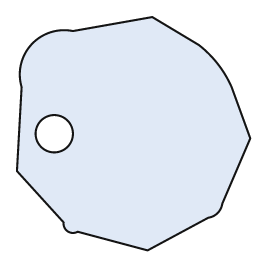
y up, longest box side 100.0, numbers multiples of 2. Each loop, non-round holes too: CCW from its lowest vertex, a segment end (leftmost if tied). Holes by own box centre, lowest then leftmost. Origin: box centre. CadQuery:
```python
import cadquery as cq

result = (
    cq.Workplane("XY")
    .moveTo(6.0, -50.0)
    .lineTo(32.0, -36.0)
    .threePointArc((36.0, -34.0), (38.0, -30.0))
    .lineTo(50.0, -2.0)
    .lineTo(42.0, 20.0)
    .threePointArc((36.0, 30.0), (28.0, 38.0))
    .lineTo(8.0, 50.0)
    .lineTo(-26.0, 44.0)
    .threePointArc((-44.0, 38.0), (-48.0, 20.0))
    .lineTo(-50.0, -16.0)
    .lineTo(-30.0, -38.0)
    .threePointArc((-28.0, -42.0), (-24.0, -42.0))
    .close()
    .moveTo(-34.0, 0.0)
    .circle(8.0)
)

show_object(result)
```